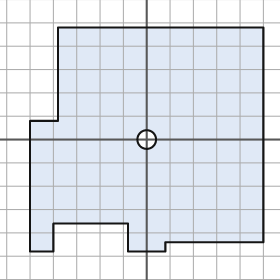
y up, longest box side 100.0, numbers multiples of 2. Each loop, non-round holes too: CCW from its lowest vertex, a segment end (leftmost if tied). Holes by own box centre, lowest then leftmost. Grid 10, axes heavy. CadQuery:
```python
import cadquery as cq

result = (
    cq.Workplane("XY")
    .moveTo(-50.0, -48.0)
    .lineTo(-40.0, -48.0)
    .lineTo(-40.0, -36.0)
    .lineTo(-8.0, -36.0)
    .lineTo(-8.0, -48.0)
    .lineTo(8.0, -48.0)
    .lineTo(8.0, -44.0)
    .lineTo(50.0, -44.0)
    .lineTo(50.0, 48.0)
    .lineTo(-38.0, 48.0)
    .lineTo(-38.0, 8.0)
    .lineTo(-50.0, 8.0)
    .close()
    .moveTo(0.0, 0.0)
    .circle(4.0)
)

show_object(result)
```